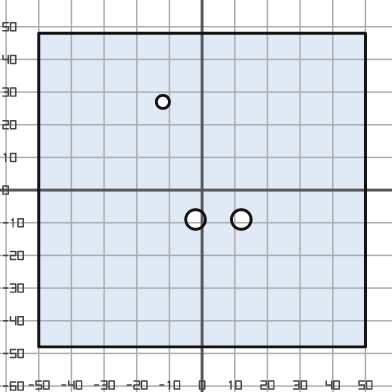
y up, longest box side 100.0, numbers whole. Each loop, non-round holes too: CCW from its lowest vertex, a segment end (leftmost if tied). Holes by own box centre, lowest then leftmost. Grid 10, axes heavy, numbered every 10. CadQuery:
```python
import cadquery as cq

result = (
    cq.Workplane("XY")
    .moveTo(-50.0, -48.0)
    .lineTo(50.0, -48.0)
    .lineTo(50.0, 48.0)
    .lineTo(-50.0, 48.0)
    .close()
    .moveTo(-2.0, -9.0)
    .circle(3.0)
    .moveTo(12.0, -9.0)
    .circle(3.0)
    .moveTo(-12.0, 27.0)
    .circle(2.0)
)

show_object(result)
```